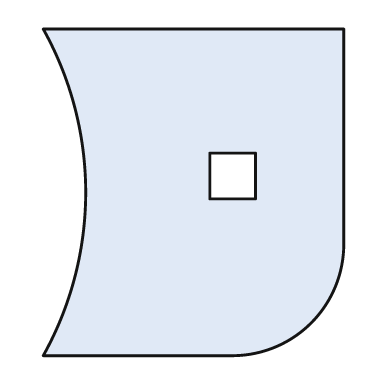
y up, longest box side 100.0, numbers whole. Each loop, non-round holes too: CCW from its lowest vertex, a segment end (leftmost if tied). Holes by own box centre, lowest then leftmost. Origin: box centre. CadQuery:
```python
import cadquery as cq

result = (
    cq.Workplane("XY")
    .moveTo(-46.0, -50.0)
    .lineTo(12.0, -50.0)
    .threePointArc((36.0, -40.0), (46.0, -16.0))
    .lineTo(46.0, 50.0)
    .lineTo(-46.0, 50.0)
    .threePointArc((-33.0, 0.0), (-46.0, -50.0))
    .close()
    .moveTo(5.0, -2.0)
    .lineTo(19.0, -2.0)
    .lineTo(19.0, 12.0)
    .lineTo(5.0, 12.0)
    .close()
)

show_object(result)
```